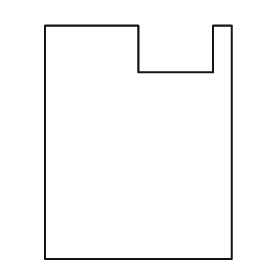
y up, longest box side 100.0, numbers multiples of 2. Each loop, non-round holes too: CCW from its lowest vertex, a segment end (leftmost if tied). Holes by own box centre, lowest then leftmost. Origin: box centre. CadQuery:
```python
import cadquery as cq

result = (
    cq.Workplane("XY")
    .moveTo(-40.0, -50.0)
    .lineTo(40.0, -50.0)
    .lineTo(40.0, 50.0)
    .lineTo(32.0, 50.0)
    .lineTo(32.0, 30.0)
    .lineTo(0.0, 30.0)
    .lineTo(0.0, 50.0)
    .lineTo(-40.0, 50.0)
    .close()
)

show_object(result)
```